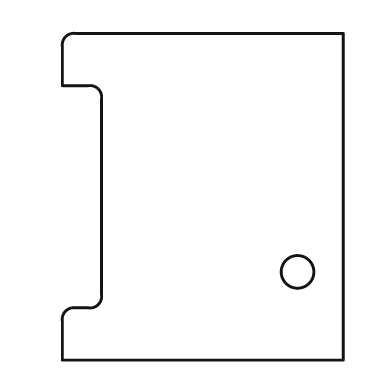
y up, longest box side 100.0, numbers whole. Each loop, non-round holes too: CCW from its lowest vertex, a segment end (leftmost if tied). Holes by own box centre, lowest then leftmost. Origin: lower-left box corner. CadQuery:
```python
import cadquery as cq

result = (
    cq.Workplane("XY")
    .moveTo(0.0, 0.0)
    .lineTo(86.0, 0.0)
    .lineTo(86.0, 100.0)
    .lineTo(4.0, 100.0)
    .threePointArc((1.0, 99.0), (0.0, 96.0))
    .lineTo(0.0, 84.0)
    .lineTo(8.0, 84.0)
    .threePointArc((11.0, 83.0), (12.0, 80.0))
    .lineTo(12.0, 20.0)
    .threePointArc((11.0, 17.0), (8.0, 16.0))
    .lineTo(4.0, 16.0)
    .threePointArc((1.0, 15.0), (0.0, 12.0))
    .close()
    .moveTo(72.0, 27.0)
    .circle(5.0)
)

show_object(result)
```